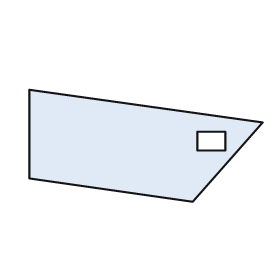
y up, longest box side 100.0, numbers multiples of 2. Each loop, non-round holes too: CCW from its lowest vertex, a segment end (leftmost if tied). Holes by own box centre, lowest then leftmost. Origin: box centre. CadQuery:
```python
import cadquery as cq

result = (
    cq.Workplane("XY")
    .moveTo(20.0, -24.0)
    .lineTo(50.0, 10.0)
    .lineTo(-50.0, 24.0)
    .lineTo(-50.0, -14.0)
    .close()
    .moveTo(22.0, -2.0)
    .lineTo(34.0, -2.0)
    .lineTo(34.0, 6.0)
    .lineTo(22.0, 6.0)
    .close()
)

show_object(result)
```